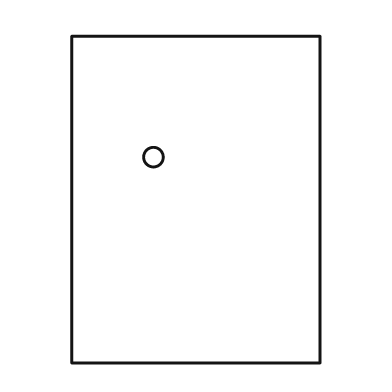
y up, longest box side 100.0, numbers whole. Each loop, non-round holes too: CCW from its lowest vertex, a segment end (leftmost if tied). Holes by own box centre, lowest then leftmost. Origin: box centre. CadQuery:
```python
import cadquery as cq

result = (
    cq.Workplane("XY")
    .moveTo(-38.0, -50.0)
    .lineTo(38.0, -50.0)
    .lineTo(38.0, 50.0)
    .lineTo(-38.0, 50.0)
    .close()
    .moveTo(-13.0, 13.0)
    .circle(3.0)
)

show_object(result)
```